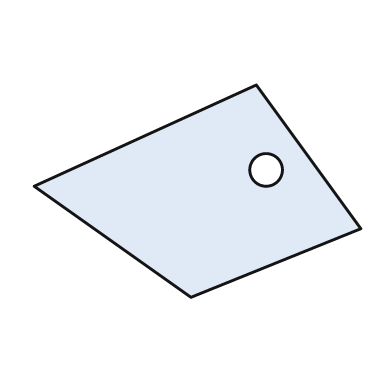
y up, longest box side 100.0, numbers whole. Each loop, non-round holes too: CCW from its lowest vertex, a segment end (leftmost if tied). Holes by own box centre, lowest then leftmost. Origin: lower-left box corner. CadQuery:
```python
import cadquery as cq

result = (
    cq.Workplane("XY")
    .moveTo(48.0, 0.0)
    .lineTo(100.0, 21.0)
    .lineTo(68.0, 65.0)
    .lineTo(0.0, 34.0)
    .close()
    .moveTo(71.0, 39.0)
    .circle(5.0)
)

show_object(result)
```